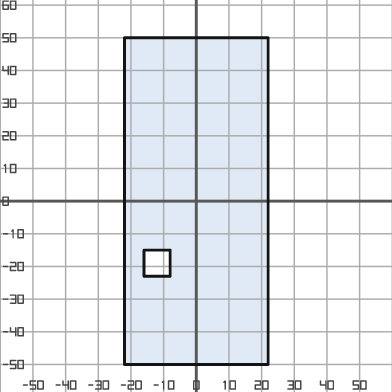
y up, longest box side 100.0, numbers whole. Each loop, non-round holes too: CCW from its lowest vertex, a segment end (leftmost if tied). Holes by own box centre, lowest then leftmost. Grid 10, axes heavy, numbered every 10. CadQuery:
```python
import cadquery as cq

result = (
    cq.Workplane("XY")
    .moveTo(-22.0, -50.0)
    .lineTo(22.0, -50.0)
    .lineTo(22.0, 50.0)
    .lineTo(-22.0, 50.0)
    .close()
    .moveTo(-16.0, -23.0)
    .lineTo(-8.0, -23.0)
    .lineTo(-8.0, -15.0)
    .lineTo(-16.0, -15.0)
    .close()
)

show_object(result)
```